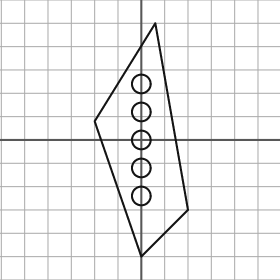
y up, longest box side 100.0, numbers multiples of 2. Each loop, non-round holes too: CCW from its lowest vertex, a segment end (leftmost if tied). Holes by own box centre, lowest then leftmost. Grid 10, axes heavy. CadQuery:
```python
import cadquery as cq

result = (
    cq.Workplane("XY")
    .moveTo(0.0, -50.0)
    .lineTo(20.0, -30.0)
    .lineTo(6.0, 50.0)
    .lineTo(-20.0, 8.0)
    .close()
    .moveTo(0.0, -24.0)
    .circle(4.0)
    .moveTo(0.0, -12.0)
    .circle(4.0)
    .moveTo(0.0, 0.0)
    .circle(4.0)
    .moveTo(0.0, 12.0)
    .circle(4.0)
    .moveTo(0.0, 24.0)
    .circle(4.0)
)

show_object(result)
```